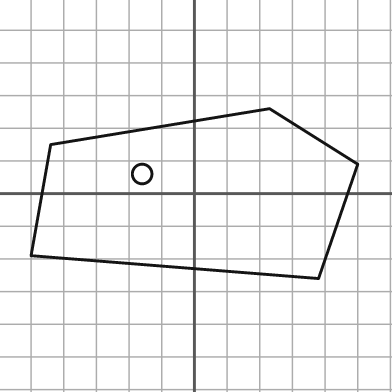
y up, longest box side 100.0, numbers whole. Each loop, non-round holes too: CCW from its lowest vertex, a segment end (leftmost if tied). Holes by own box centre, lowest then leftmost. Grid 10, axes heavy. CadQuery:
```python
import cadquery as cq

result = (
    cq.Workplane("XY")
    .moveTo(38.0, -26.0)
    .lineTo(50.0, 9.0)
    .lineTo(23.0, 26.0)
    .lineTo(-44.0, 15.0)
    .lineTo(-50.0, -19.0)
    .close()
    .moveTo(-16.0, 6.0)
    .circle(3.0)
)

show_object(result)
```